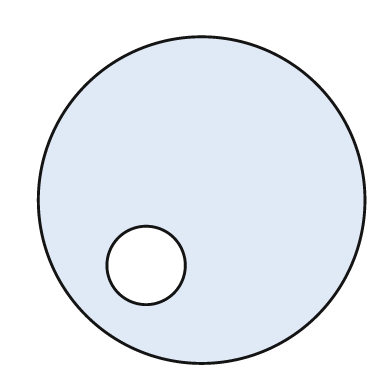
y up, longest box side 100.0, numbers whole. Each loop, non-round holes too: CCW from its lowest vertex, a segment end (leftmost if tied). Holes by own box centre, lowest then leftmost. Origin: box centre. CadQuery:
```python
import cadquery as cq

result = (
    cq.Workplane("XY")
    .moveTo(0.0, 0.0)
    .circle(50.0)
    .moveTo(-17.0, -20.0)
    .circle(12.0)
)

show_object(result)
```